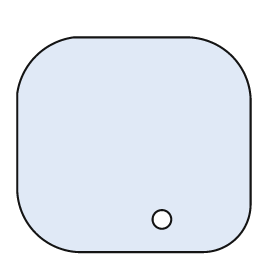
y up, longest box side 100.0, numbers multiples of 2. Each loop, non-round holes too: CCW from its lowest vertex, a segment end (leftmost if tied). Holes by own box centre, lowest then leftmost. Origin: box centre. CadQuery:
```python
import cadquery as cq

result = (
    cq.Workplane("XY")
    .moveTo(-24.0, -46.0)
    .lineTo(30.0, -46.0)
    .threePointArc((44.0, -40.0), (50.0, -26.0))
    .lineTo(50.0, 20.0)
    .threePointArc((42.0, 38.0), (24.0, 46.0))
    .lineTo(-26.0, 46.0)
    .threePointArc((-42.0, 38.0), (-50.0, 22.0))
    .lineTo(-50.0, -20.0)
    .threePointArc((-42.0, -38.0), (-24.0, -46.0))
    .close()
    .moveTo(12.0, -32.0)
    .circle(4.0)
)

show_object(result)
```